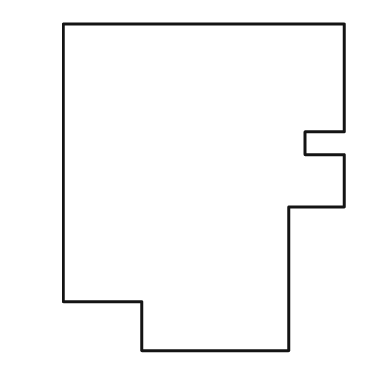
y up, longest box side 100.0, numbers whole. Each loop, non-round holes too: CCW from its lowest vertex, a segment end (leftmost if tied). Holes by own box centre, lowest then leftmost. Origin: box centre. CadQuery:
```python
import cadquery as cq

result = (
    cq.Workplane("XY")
    .moveTo(-19.0, -50.0)
    .lineTo(26.0, -50.0)
    .lineTo(26.0, -6.0)
    .lineTo(43.0, -6.0)
    .lineTo(43.0, 10.0)
    .lineTo(31.0, 10.0)
    .lineTo(31.0, 17.0)
    .lineTo(43.0, 17.0)
    .lineTo(43.0, 50.0)
    .lineTo(-43.0, 50.0)
    .lineTo(-43.0, -35.0)
    .lineTo(-19.0, -35.0)
    .close()
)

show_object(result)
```